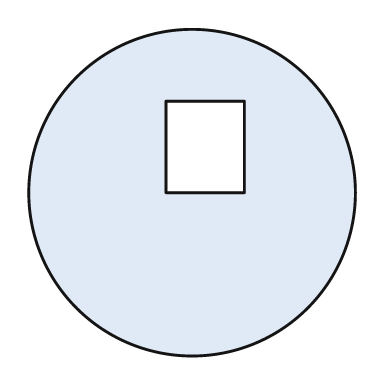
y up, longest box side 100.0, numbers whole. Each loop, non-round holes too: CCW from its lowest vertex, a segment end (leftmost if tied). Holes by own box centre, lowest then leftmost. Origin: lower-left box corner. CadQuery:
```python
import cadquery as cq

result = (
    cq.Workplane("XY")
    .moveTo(50.0, 50.0)
    .circle(50.0)
    .moveTo(42.0, 50.0)
    .lineTo(66.0, 50.0)
    .lineTo(66.0, 78.0)
    .lineTo(42.0, 78.0)
    .close()
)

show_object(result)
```